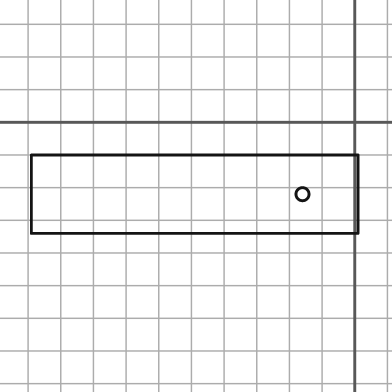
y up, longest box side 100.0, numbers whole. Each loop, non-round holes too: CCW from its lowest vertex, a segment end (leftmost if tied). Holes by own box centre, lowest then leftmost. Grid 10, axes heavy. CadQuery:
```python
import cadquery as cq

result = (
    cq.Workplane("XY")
    .moveTo(-99.0, -34.0)
    .lineTo(1.0, -34.0)
    .lineTo(1.0, -10.0)
    .lineTo(-99.0, -10.0)
    .close()
    .moveTo(-16.0, -22.0)
    .circle(2.0)
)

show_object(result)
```